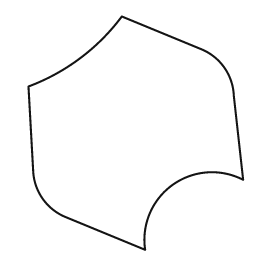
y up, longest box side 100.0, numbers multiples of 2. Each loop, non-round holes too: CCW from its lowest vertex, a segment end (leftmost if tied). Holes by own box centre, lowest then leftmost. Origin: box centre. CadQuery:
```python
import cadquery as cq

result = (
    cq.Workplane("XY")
    .moveTo(4.0, -50.0)
    .threePointArc((16.0, -22.0), (46.0, -20.0))
    .lineTo(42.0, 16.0)
    .threePointArc((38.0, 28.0), (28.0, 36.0))
    .lineTo(-6.0, 50.0)
    .threePointArc((-24.0, 32.0), (-46.0, 20.0))
    .lineTo(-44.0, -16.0)
    .threePointArc((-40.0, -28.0), (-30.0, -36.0))
    .close()
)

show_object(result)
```